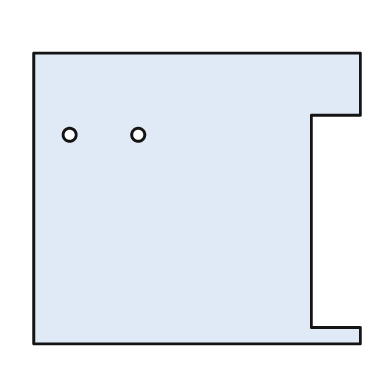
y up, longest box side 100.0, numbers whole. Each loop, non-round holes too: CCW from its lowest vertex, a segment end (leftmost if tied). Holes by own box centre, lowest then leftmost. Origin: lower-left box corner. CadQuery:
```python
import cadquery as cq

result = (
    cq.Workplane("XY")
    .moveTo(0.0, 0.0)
    .lineTo(100.0, 0.0)
    .lineTo(100.0, 5.0)
    .lineTo(85.0, 5.0)
    .lineTo(85.0, 70.0)
    .lineTo(100.0, 70.0)
    .lineTo(100.0, 89.0)
    .lineTo(0.0, 89.0)
    .close()
    .moveTo(11.0, 64.0)
    .circle(2.0)
    .moveTo(32.0, 64.0)
    .circle(2.0)
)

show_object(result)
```